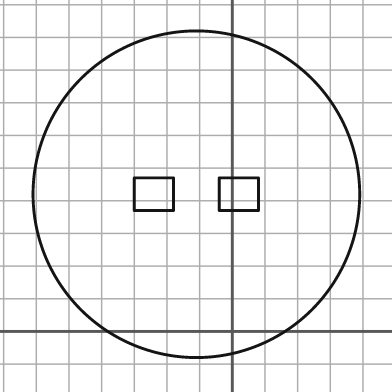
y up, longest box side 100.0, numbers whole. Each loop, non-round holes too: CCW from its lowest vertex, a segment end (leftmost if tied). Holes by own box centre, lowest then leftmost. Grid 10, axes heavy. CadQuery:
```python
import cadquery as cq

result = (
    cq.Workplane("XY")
    .moveTo(-11.0, 42.0)
    .circle(50.0)
    .moveTo(-30.0, 37.0)
    .lineTo(-18.0, 37.0)
    .lineTo(-18.0, 47.0)
    .lineTo(-30.0, 47.0)
    .close()
    .moveTo(-4.0, 37.0)
    .lineTo(8.0, 37.0)
    .lineTo(8.0, 47.0)
    .lineTo(-4.0, 47.0)
    .close()
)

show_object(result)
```